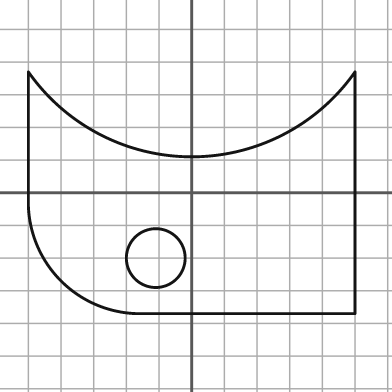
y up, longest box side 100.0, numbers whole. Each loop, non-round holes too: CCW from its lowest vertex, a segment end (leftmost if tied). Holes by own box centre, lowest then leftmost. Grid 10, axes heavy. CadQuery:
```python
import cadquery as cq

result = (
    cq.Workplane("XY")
    .moveTo(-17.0, -37.0)
    .lineTo(50.0, -37.0)
    .lineTo(50.0, 37.0)
    .threePointArc((0.0, 11.0), (-50.0, 37.0))
    .lineTo(-50.0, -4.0)
    .threePointArc((-40.0, -27.0), (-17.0, -37.0))
    .close()
    .moveTo(-11.0, -20.0)
    .circle(9.0)
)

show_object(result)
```